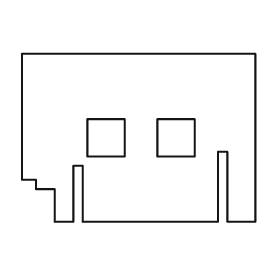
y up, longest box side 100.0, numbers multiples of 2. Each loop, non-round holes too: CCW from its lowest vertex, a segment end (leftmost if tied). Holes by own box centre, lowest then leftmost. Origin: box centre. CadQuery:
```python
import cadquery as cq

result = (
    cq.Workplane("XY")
    .moveTo(-36.0, -36.0)
    .lineTo(-28.0, -36.0)
    .lineTo(-28.0, -12.0)
    .lineTo(-24.0, -12.0)
    .lineTo(-24.0, -36.0)
    .lineTo(34.0, -36.0)
    .lineTo(34.0, -6.0)
    .lineTo(38.0, -6.0)
    .lineTo(38.0, -36.0)
    .lineTo(50.0, -36.0)
    .lineTo(50.0, 36.0)
    .lineTo(-50.0, 36.0)
    .lineTo(-50.0, -18.0)
    .lineTo(-44.0, -18.0)
    .lineTo(-44.0, -22.0)
    .lineTo(-36.0, -22.0)
    .close()
    .moveTo(-22.0, -8.0)
    .lineTo(-6.0, -8.0)
    .lineTo(-6.0, 8.0)
    .lineTo(-22.0, 8.0)
    .close()
    .moveTo(8.0, -8.0)
    .lineTo(24.0, -8.0)
    .lineTo(24.0, 8.0)
    .lineTo(8.0, 8.0)
    .close()
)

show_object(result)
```